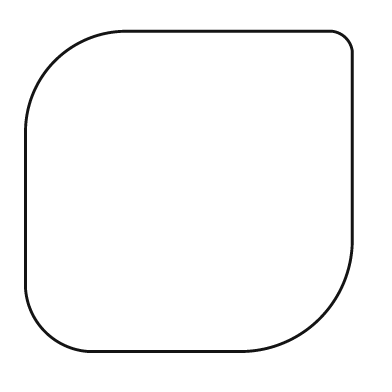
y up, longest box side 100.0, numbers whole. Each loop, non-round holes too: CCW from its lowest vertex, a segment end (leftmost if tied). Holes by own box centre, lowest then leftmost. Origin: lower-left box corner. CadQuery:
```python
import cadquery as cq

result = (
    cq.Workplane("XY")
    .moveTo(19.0, 0.0)
    .lineTo(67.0, 0.0)
    .threePointArc((90.0, 10.0), (100.0, 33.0))
    .lineTo(100.0, 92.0)
    .threePointArc((98.0, 96.0), (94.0, 98.0))
    .lineTo(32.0, 98.0)
    .threePointArc((9.0, 89.0), (0.0, 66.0))
    .lineTo(0.0, 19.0)
    .threePointArc((6.0, 6.0), (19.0, 0.0))
    .close()
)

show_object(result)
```